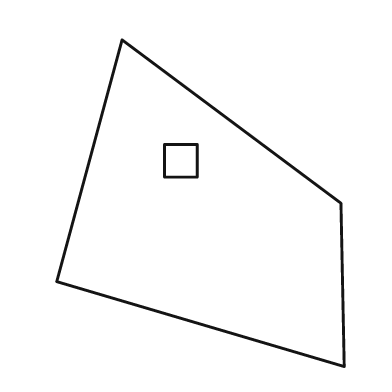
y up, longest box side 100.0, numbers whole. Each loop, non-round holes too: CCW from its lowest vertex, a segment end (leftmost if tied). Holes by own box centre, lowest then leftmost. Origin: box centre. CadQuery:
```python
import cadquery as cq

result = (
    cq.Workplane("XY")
    .moveTo(44.0, -50.0)
    .lineTo(43.0, 0.0)
    .lineTo(-24.0, 50.0)
    .lineTo(-44.0, -24.0)
    .close()
    .moveTo(-11.0, 8.0)
    .lineTo(-1.0, 8.0)
    .lineTo(-1.0, 18.0)
    .lineTo(-11.0, 18.0)
    .close()
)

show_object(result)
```